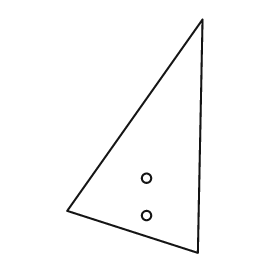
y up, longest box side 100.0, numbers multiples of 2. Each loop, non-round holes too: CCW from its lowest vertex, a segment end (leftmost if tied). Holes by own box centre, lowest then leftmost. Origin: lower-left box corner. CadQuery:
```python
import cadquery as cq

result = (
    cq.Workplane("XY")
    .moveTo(56.0, 0.0)
    .lineTo(58.0, 100.0)
    .lineTo(0.0, 18.0)
    .close()
    .moveTo(34.0, 16.0)
    .circle(2.0)
    .moveTo(34.0, 32.0)
    .circle(2.0)
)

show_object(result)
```